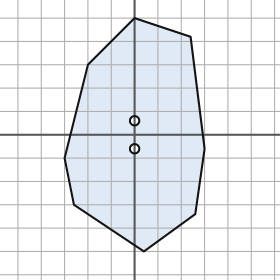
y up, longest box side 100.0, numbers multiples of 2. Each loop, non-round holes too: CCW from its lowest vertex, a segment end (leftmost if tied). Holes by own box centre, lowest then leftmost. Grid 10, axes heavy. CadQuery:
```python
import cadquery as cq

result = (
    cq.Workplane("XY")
    .moveTo(4.0, -50.0)
    .lineTo(26.0, -34.0)
    .lineTo(30.0, -6.0)
    .lineTo(24.0, 42.0)
    .lineTo(0.0, 50.0)
    .lineTo(-20.0, 30.0)
    .lineTo(-30.0, -10.0)
    .lineTo(-26.0, -30.0)
    .close()
    .moveTo(0.0, -6.0)
    .circle(2.0)
    .moveTo(0.0, 6.0)
    .circle(2.0)
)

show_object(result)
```